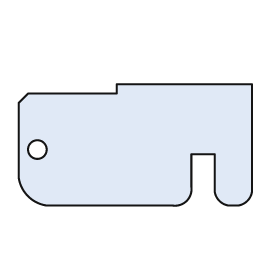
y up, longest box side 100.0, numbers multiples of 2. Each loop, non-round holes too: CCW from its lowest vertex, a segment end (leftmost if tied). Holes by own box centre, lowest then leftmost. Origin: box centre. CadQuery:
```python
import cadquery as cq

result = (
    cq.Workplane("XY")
    .moveTo(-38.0, -26.0)
    .lineTo(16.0, -26.0)
    .threePointArc((22.0, -24.0), (24.0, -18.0))
    .lineTo(24.0, -4.0)
    .lineTo(34.0, -4.0)
    .lineTo(34.0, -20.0)
    .threePointArc((36.0, -24.0), (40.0, -26.0))
    .lineTo(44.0, -26.0)
    .threePointArc((48.0, -24.0), (50.0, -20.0))
    .lineTo(50.0, 26.0)
    .lineTo(-8.0, 26.0)
    .lineTo(-8.0, 22.0)
    .lineTo(-46.0, 22.0)
    .lineTo(-50.0, 18.0)
    .lineTo(-50.0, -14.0)
    .threePointArc((-46.0, -22.0), (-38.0, -26.0))
    .close()
    .moveTo(-42.0, -2.0)
    .circle(4.0)
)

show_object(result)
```